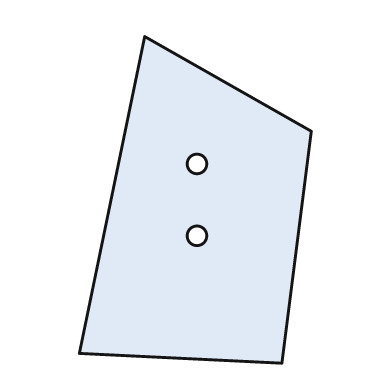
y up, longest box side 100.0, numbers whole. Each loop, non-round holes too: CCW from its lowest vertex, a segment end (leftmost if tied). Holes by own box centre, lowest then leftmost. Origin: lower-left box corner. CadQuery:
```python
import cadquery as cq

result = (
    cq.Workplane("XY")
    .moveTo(62.0, 0.0)
    .lineTo(71.0, 71.0)
    .lineTo(20.0, 100.0)
    .lineTo(0.0, 3.0)
    .close()
    .moveTo(36.0, 39.0)
    .circle(3.0)
    .moveTo(36.0, 61.0)
    .circle(3.0)
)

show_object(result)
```